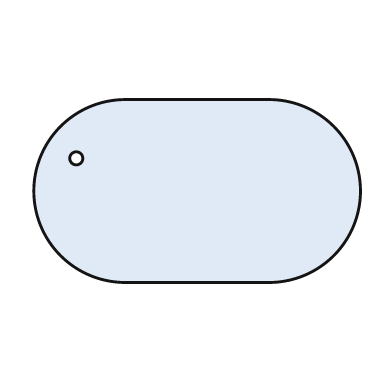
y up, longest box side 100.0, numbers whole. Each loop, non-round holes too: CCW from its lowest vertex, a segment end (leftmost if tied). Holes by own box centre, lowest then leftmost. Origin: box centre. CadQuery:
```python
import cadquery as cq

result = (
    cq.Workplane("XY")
    .moveTo(-22.0, -28.0)
    .lineTo(22.0, -28.0)
    .threePointArc((50.0, 0.0), (22.0, 28.0))
    .lineTo(-22.0, 28.0)
    .threePointArc((-50.0, 0.0), (-22.0, -28.0))
    .close()
    .moveTo(-37.0, 10.0)
    .circle(2.0)
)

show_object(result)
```